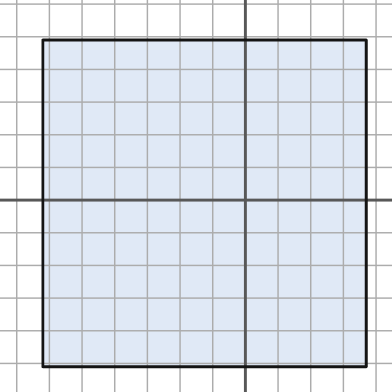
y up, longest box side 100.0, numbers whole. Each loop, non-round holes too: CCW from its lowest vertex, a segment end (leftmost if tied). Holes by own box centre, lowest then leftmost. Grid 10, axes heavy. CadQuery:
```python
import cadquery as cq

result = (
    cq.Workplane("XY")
    .moveTo(-62.0, -51.0)
    .lineTo(37.0, -51.0)
    .lineTo(37.0, 49.0)
    .lineTo(-62.0, 49.0)
    .close()
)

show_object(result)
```